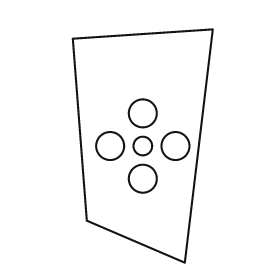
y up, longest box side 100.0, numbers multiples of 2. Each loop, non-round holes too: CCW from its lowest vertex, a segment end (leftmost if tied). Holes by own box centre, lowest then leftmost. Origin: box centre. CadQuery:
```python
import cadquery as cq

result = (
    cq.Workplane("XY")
    .moveTo(18.0, -50.0)
    .lineTo(30.0, 50.0)
    .lineTo(-30.0, 46.0)
    .lineTo(-24.0, -32.0)
    .close()
    .moveTo(0.0, -14.0)
    .circle(6.0)
    .moveTo(-14.0, 0.0)
    .circle(6.0)
    .moveTo(0.0, 0.0)
    .circle(4.0)
    .moveTo(14.0, 0.0)
    .circle(6.0)
    .moveTo(0.0, 14.0)
    .circle(6.0)
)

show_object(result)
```